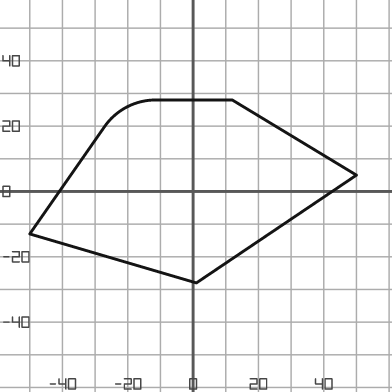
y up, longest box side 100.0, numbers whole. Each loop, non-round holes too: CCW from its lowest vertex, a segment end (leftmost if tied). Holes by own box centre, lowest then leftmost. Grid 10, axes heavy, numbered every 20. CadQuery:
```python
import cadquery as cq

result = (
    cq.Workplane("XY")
    .moveTo(1.0, -28.0)
    .lineTo(50.0, 5.0)
    .lineTo(12.0, 28.0)
    .lineTo(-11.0, 28.0)
    .threePointArc((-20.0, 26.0), (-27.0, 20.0))
    .lineTo(-50.0, -13.0)
    .close()
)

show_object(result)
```